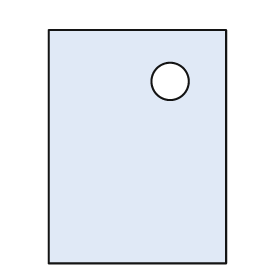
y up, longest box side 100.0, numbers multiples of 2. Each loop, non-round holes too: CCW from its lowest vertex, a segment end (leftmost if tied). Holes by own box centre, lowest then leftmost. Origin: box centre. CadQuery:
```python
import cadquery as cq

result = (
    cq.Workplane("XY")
    .moveTo(-38.0, -50.0)
    .lineTo(38.0, -50.0)
    .lineTo(38.0, 50.0)
    .lineTo(-38.0, 50.0)
    .close()
    .moveTo(14.0, 28.0)
    .circle(8.0)
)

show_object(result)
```